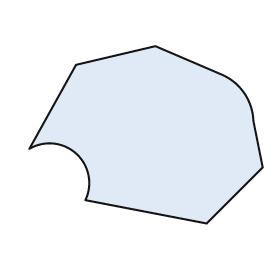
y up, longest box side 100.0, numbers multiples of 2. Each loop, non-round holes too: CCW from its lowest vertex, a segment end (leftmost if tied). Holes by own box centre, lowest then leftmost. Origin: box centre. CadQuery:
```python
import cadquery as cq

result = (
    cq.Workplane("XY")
    .moveTo(26.0, -38.0)
    .lineTo(50.0, -14.0)
    .lineTo(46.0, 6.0)
    .threePointArc((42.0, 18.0), (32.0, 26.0))
    .lineTo(4.0, 38.0)
    .lineTo(-30.0, 30.0)
    .lineTo(-50.0, -6.0)
    .threePointArc((-30.0, -8.0), (-26.0, -28.0))
    .close()
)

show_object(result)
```